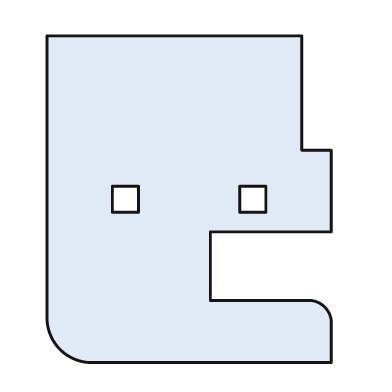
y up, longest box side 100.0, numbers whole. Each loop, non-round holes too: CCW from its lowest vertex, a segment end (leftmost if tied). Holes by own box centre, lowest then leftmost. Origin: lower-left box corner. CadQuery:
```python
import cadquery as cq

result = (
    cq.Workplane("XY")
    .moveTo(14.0, 0.0)
    .lineTo(87.0, 0.0)
    .lineTo(87.0, 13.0)
    .threePointArc((85.0, 17.0), (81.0, 19.0))
    .lineTo(50.0, 19.0)
    .lineTo(50.0, 40.0)
    .lineTo(87.0, 40.0)
    .lineTo(87.0, 65.0)
    .lineTo(78.0, 65.0)
    .lineTo(78.0, 100.0)
    .lineTo(0.0, 100.0)
    .lineTo(0.0, 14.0)
    .threePointArc((4.0, 4.0), (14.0, 0.0))
    .close()
    .moveTo(20.0, 46.0)
    .lineTo(28.0, 46.0)
    .lineTo(28.0, 54.0)
    .lineTo(20.0, 54.0)
    .close()
    .moveTo(59.0, 46.0)
    .lineTo(67.0, 46.0)
    .lineTo(67.0, 54.0)
    .lineTo(59.0, 54.0)
    .close()
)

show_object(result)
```